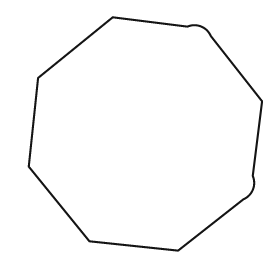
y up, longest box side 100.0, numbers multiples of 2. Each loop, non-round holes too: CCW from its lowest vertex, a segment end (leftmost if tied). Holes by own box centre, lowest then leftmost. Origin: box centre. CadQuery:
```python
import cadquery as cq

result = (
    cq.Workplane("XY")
    .moveTo(14.0, -50.0)
    .lineTo(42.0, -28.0)
    .threePointArc((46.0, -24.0), (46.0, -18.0))
    .lineTo(50.0, 14.0)
    .lineTo(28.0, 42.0)
    .threePointArc((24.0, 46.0), (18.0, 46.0))
    .lineTo(-14.0, 50.0)
    .lineTo(-46.0, 24.0)
    .lineTo(-50.0, -14.0)
    .lineTo(-24.0, -46.0)
    .close()
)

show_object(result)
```